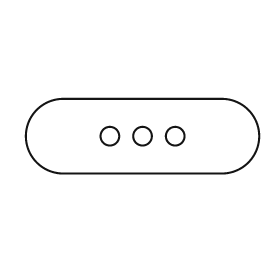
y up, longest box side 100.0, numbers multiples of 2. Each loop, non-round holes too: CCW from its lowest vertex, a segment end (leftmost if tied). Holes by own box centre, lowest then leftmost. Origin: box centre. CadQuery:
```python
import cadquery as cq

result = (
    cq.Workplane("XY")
    .moveTo(-34.0, -16.0)
    .lineTo(34.0, -16.0)
    .threePointArc((50.0, 0.0), (34.0, 16.0))
    .lineTo(-34.0, 16.0)
    .threePointArc((-50.0, 0.0), (-34.0, -16.0))
    .close()
    .moveTo(-14.0, 0.0)
    .circle(4.0)
    .moveTo(0.0, 0.0)
    .circle(4.0)
    .moveTo(14.0, 0.0)
    .circle(4.0)
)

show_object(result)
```